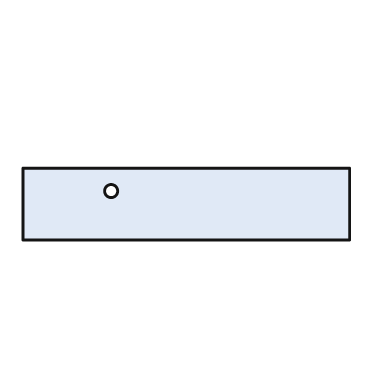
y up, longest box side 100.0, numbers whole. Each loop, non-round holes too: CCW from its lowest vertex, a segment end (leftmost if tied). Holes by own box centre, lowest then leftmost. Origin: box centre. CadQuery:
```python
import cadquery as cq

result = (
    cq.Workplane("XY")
    .moveTo(-50.0, -11.0)
    .lineTo(50.0, -11.0)
    .lineTo(50.0, 11.0)
    .lineTo(-50.0, 11.0)
    .close()
    .moveTo(-23.0, 4.0)
    .circle(2.0)
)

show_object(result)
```